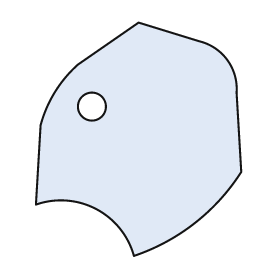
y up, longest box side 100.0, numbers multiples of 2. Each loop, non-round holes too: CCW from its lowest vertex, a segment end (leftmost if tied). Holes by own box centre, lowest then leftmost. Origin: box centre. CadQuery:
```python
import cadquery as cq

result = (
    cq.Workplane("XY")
    .moveTo(-2.0, -50.0)
    .threePointArc((24.0, -36.0), (44.0, -14.0))
    .lineTo(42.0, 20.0)
    .threePointArc((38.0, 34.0), (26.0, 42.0))
    .lineTo(0.0, 50.0)
    .lineTo(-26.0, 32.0)
    .threePointArc((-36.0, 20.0), (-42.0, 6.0))
    .lineTo(-44.0, -28.0)
    .threePointArc((-18.0, -30.0), (-2.0, -50.0))
    .close()
    .moveTo(-20.0, 14.0)
    .circle(6.0)
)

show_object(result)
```